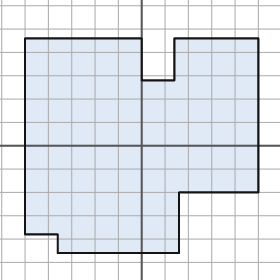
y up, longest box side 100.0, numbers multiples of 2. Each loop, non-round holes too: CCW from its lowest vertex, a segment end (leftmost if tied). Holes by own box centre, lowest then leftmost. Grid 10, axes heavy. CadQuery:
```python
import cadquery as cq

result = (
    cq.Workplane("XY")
    .moveTo(-36.0, -46.0)
    .lineTo(16.0, -46.0)
    .lineTo(16.0, -20.0)
    .lineTo(50.0, -20.0)
    .lineTo(50.0, 46.0)
    .lineTo(14.0, 46.0)
    .lineTo(14.0, 28.0)
    .lineTo(0.0, 28.0)
    .lineTo(0.0, 46.0)
    .lineTo(-50.0, 46.0)
    .lineTo(-50.0, -38.0)
    .lineTo(-36.0, -38.0)
    .close()
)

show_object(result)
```